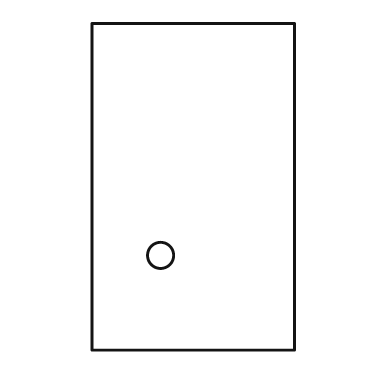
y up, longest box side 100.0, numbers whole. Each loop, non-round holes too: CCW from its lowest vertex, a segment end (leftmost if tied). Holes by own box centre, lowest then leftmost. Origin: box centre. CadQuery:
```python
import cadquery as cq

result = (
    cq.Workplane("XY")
    .moveTo(-31.0, -50.0)
    .lineTo(31.0, -50.0)
    .lineTo(31.0, 50.0)
    .lineTo(-31.0, 50.0)
    .close()
    .moveTo(-10.0, -21.0)
    .circle(4.0)
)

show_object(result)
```